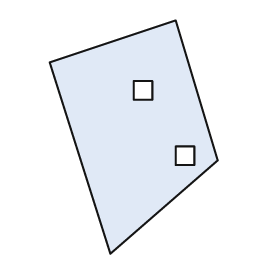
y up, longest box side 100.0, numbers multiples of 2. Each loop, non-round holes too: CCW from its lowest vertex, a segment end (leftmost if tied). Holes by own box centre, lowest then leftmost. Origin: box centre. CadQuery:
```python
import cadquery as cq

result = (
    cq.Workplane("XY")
    .moveTo(-10.0, -50.0)
    .lineTo(36.0, -10.0)
    .lineTo(18.0, 50.0)
    .lineTo(-36.0, 32.0)
    .close()
    .moveTo(18.0, -12.0)
    .lineTo(26.0, -12.0)
    .lineTo(26.0, -4.0)
    .lineTo(18.0, -4.0)
    .close()
    .moveTo(0.0, 16.0)
    .lineTo(8.0, 16.0)
    .lineTo(8.0, 24.0)
    .lineTo(0.0, 24.0)
    .close()
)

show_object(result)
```